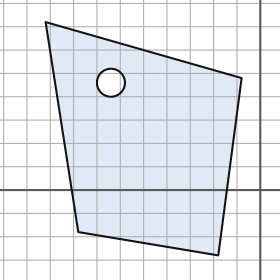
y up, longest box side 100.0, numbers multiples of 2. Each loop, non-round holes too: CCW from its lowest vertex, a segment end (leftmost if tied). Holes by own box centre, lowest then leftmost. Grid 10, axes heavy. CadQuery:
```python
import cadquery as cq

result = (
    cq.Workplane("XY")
    .moveTo(-18.0, -28.0)
    .lineTo(-8.0, 48.0)
    .lineTo(-92.0, 72.0)
    .lineTo(-78.0, -18.0)
    .close()
    .moveTo(-64.0, 46.0)
    .circle(6.0)
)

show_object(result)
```